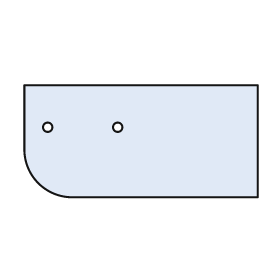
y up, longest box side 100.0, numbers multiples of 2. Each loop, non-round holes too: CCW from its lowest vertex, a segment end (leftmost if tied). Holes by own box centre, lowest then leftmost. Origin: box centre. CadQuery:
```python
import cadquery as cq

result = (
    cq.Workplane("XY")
    .moveTo(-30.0, -24.0)
    .lineTo(50.0, -24.0)
    .lineTo(50.0, 24.0)
    .lineTo(-50.0, 24.0)
    .lineTo(-50.0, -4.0)
    .threePointArc((-44.0, -18.0), (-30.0, -24.0))
    .close()
    .moveTo(-40.0, 6.0)
    .circle(2.0)
    .moveTo(-10.0, 6.0)
    .circle(2.0)
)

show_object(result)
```